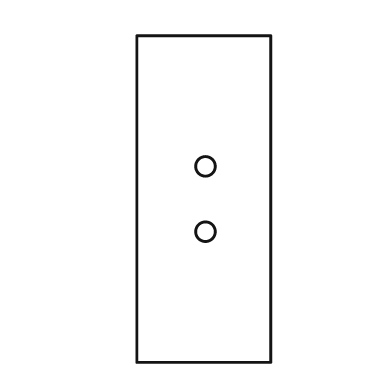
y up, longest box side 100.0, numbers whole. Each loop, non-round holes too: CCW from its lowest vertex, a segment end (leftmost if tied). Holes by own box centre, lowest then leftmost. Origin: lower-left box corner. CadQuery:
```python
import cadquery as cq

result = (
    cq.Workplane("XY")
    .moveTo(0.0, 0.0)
    .lineTo(41.0, 0.0)
    .lineTo(41.0, 100.0)
    .lineTo(0.0, 100.0)
    .close()
    .moveTo(21.0, 40.0)
    .circle(3.0)
    .moveTo(21.0, 60.0)
    .circle(3.0)
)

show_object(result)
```